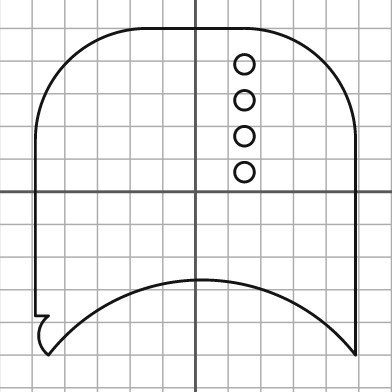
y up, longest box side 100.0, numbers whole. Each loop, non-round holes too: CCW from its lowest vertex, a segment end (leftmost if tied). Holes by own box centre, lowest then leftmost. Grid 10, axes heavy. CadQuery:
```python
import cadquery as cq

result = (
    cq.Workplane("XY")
    .moveTo(-45.0, -50.0)
    .threePointArc((2.0, -27.0), (49.0, -50.0))
    .lineTo(49.0, 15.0)
    .threePointArc((39.0, 40.0), (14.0, 50.0))
    .lineTo(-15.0, 50.0)
    .threePointArc((-39.0, 40.0), (-49.0, 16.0))
    .lineTo(-49.0, -38.0)
    .lineTo(-45.0, -38.0)
    .threePointArc((-48.0, -44.0), (-45.0, -50.0))
    .close()
    .moveTo(15.0, 6.0)
    .circle(3.0)
    .moveTo(15.0, 17.0)
    .circle(3.0)
    .moveTo(15.0, 28.0)
    .circle(3.0)
    .moveTo(15.0, 39.0)
    .circle(3.0)
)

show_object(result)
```